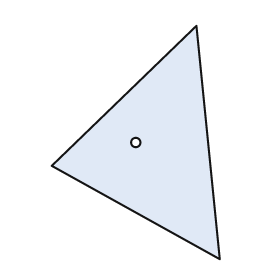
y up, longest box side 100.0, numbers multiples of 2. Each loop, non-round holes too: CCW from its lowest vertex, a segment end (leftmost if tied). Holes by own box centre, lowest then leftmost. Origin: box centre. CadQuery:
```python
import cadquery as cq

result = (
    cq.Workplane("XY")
    .moveTo(36.0, -50.0)
    .lineTo(26.0, 50.0)
    .lineTo(-36.0, -10.0)
    .close()
    .moveTo(0.0, 0.0)
    .circle(2.0)
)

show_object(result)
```